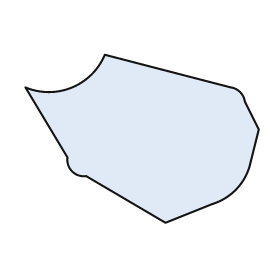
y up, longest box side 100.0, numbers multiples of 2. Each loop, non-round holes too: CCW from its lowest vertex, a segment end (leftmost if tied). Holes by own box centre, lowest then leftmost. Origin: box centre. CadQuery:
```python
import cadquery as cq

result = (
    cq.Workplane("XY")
    .moveTo(10.0, -36.0)
    .lineTo(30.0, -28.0)
    .threePointArc((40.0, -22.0), (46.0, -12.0))
    .lineTo(50.0, 4.0)
    .lineTo(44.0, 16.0)
    .threePointArc((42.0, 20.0), (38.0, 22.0))
    .lineTo(-16.0, 36.0)
    .threePointArc((-30.0, 22.0), (-50.0, 22.0))
    .lineTo(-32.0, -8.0)
    .threePointArc((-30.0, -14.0), (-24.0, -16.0))
    .close()
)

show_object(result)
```